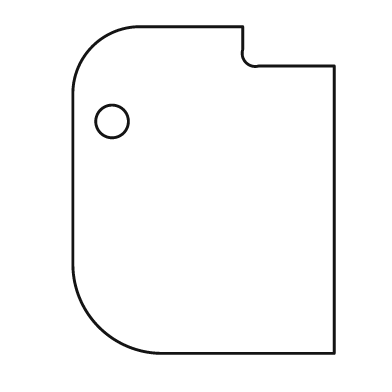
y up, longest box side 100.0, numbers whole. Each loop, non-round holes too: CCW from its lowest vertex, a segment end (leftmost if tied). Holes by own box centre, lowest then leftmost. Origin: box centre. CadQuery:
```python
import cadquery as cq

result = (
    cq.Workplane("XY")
    .moveTo(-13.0, -50.0)
    .lineTo(40.0, -50.0)
    .lineTo(40.0, 38.0)
    .lineTo(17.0, 38.0)
    .threePointArc((13.0, 39.0), (12.0, 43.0))
    .lineTo(12.0, 50.0)
    .lineTo(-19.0, 50.0)
    .threePointArc((-34.0, 44.0), (-40.0, 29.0))
    .lineTo(-40.0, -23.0)
    .threePointArc((-32.0, -42.0), (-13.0, -50.0))
    .close()
    .moveTo(-28.0, 21.0)
    .circle(5.0)
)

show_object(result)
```